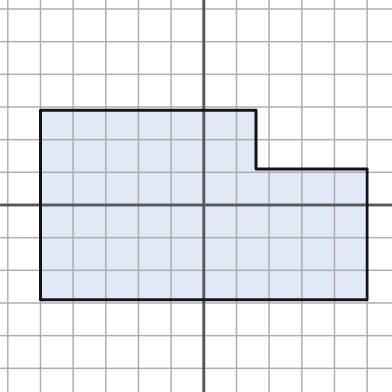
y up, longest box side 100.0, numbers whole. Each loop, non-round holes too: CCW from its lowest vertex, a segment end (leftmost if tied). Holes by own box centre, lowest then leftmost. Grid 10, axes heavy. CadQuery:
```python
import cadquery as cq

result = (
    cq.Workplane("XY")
    .moveTo(-50.0, -29.0)
    .lineTo(50.0, -29.0)
    .lineTo(50.0, 11.0)
    .lineTo(16.0, 11.0)
    .lineTo(16.0, 29.0)
    .lineTo(-50.0, 29.0)
    .close()
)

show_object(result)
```